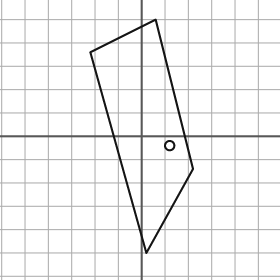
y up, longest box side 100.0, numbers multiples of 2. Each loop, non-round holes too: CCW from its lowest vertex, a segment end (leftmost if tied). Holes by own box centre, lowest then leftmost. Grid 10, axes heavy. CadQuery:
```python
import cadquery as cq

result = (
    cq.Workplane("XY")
    .moveTo(2.0, -50.0)
    .lineTo(22.0, -14.0)
    .lineTo(6.0, 50.0)
    .lineTo(-22.0, 36.0)
    .close()
    .moveTo(12.0, -4.0)
    .circle(2.0)
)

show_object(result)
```